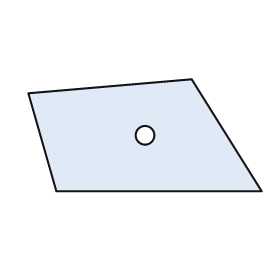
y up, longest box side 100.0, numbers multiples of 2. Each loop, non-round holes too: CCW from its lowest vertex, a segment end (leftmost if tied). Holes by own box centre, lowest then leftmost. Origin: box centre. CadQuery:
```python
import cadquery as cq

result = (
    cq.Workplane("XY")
    .moveTo(-38.0, -24.0)
    .lineTo(50.0, -24.0)
    .lineTo(20.0, 24.0)
    .lineTo(-50.0, 18.0)
    .close()
    .moveTo(0.0, 0.0)
    .circle(4.0)
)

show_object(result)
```